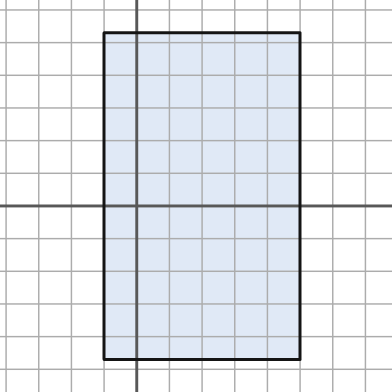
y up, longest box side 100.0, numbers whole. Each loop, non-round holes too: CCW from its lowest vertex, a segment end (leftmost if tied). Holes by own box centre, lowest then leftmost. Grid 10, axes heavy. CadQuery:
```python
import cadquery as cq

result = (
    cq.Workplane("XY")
    .moveTo(-10.0, -47.0)
    .lineTo(50.0, -47.0)
    .lineTo(50.0, 53.0)
    .lineTo(-10.0, 53.0)
    .close()
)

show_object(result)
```